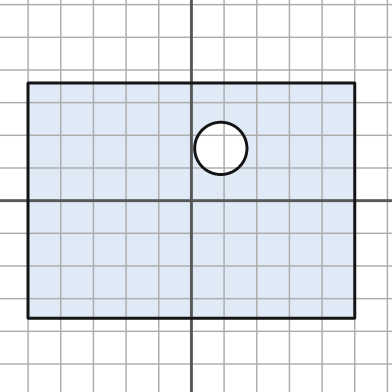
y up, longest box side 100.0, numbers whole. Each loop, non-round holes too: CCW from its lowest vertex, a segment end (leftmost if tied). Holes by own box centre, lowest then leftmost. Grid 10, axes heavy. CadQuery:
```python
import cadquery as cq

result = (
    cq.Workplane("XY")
    .moveTo(-50.0, -36.0)
    .lineTo(50.0, -36.0)
    .lineTo(50.0, 36.0)
    .lineTo(-50.0, 36.0)
    .close()
    .moveTo(9.0, 16.0)
    .circle(8.0)
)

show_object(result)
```